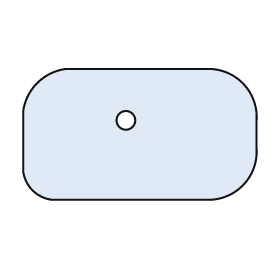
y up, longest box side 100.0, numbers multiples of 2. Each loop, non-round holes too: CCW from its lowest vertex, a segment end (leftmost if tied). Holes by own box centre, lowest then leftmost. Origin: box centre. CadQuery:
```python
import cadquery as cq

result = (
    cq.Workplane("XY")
    .moveTo(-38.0, -28.0)
    .lineTo(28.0, -28.0)
    .threePointArc((44.0, -22.0), (50.0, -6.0))
    .lineTo(50.0, 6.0)
    .threePointArc((44.0, 22.0), (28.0, 28.0))
    .lineTo(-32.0, 28.0)
    .threePointArc((-44.0, 22.0), (-50.0, 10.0))
    .lineTo(-50.0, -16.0)
    .threePointArc((-46.0, -24.0), (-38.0, -28.0))
    .close()
    .moveTo(-6.0, 6.0)
    .circle(4.0)
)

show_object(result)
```